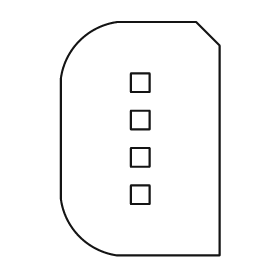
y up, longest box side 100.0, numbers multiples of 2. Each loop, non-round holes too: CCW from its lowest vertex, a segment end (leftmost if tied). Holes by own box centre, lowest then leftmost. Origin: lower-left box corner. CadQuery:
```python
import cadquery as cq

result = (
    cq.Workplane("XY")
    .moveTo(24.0, 0.0)
    .lineTo(68.0, 0.0)
    .lineTo(68.0, 90.0)
    .lineTo(58.0, 100.0)
    .lineTo(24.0, 100.0)
    .threePointArc((8.0, 92.0), (0.0, 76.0))
    .lineTo(0.0, 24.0)
    .threePointArc((8.0, 8.0), (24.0, 0.0))
    .close()
    .moveTo(30.0, 22.0)
    .lineTo(38.0, 22.0)
    .lineTo(38.0, 30.0)
    .lineTo(30.0, 30.0)
    .close()
    .moveTo(30.0, 38.0)
    .lineTo(38.0, 38.0)
    .lineTo(38.0, 46.0)
    .lineTo(30.0, 46.0)
    .close()
    .moveTo(30.0, 54.0)
    .lineTo(38.0, 54.0)
    .lineTo(38.0, 62.0)
    .lineTo(30.0, 62.0)
    .close()
    .moveTo(30.0, 70.0)
    .lineTo(38.0, 70.0)
    .lineTo(38.0, 78.0)
    .lineTo(30.0, 78.0)
    .close()
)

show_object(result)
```